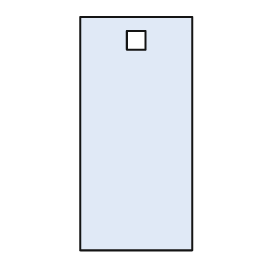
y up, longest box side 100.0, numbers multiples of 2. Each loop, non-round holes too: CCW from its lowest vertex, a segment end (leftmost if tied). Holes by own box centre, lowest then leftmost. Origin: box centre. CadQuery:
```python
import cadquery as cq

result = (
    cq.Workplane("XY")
    .moveTo(-24.0, -50.0)
    .lineTo(24.0, -50.0)
    .lineTo(24.0, 50.0)
    .lineTo(-24.0, 50.0)
    .close()
    .moveTo(-4.0, 36.0)
    .lineTo(4.0, 36.0)
    .lineTo(4.0, 44.0)
    .lineTo(-4.0, 44.0)
    .close()
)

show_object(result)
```